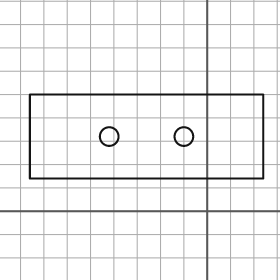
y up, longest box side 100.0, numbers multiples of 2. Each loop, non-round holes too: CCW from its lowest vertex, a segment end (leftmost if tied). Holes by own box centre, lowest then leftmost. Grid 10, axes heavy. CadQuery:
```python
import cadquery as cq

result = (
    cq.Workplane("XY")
    .moveTo(-76.0, 14.0)
    .lineTo(24.0, 14.0)
    .lineTo(24.0, 50.0)
    .lineTo(-76.0, 50.0)
    .close()
    .moveTo(-42.0, 32.0)
    .circle(4.0)
    .moveTo(-10.0, 32.0)
    .circle(4.0)
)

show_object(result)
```